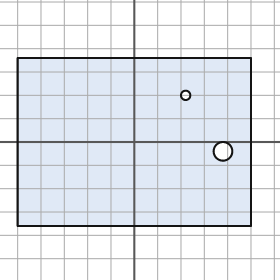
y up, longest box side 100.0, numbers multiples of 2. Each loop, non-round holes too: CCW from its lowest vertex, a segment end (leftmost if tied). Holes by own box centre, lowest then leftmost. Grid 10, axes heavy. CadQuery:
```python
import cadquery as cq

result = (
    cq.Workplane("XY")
    .moveTo(-50.0, -36.0)
    .lineTo(50.0, -36.0)
    .lineTo(50.0, 36.0)
    .lineTo(-50.0, 36.0)
    .close()
    .moveTo(38.0, -4.0)
    .circle(4.0)
    .moveTo(22.0, 20.0)
    .circle(2.0)
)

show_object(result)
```